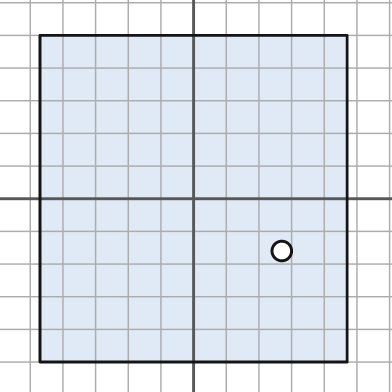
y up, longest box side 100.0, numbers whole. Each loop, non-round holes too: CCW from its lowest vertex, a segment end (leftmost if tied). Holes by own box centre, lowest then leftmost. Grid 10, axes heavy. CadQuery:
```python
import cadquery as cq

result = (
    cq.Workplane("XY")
    .moveTo(-47.0, -50.0)
    .lineTo(47.0, -50.0)
    .lineTo(47.0, 50.0)
    .lineTo(-47.0, 50.0)
    .close()
    .moveTo(27.0, -16.0)
    .circle(3.0)
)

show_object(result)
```